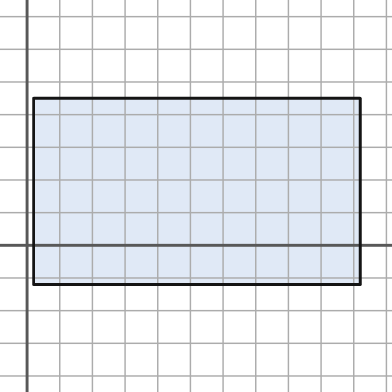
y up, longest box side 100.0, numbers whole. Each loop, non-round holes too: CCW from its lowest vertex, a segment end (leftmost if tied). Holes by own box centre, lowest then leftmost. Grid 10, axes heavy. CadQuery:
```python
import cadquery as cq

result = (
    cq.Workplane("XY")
    .moveTo(2.0, -12.0)
    .lineTo(102.0, -12.0)
    .lineTo(102.0, 45.0)
    .lineTo(2.0, 45.0)
    .close()
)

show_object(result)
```